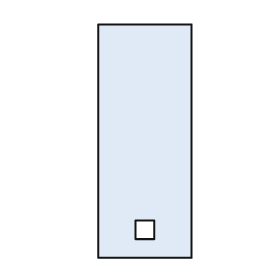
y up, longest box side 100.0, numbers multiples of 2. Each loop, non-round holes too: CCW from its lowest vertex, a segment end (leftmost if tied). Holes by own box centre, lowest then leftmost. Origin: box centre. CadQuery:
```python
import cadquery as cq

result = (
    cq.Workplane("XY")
    .moveTo(-20.0, -50.0)
    .lineTo(20.0, -50.0)
    .lineTo(20.0, 50.0)
    .lineTo(-20.0, 50.0)
    .close()
    .moveTo(-4.0, -42.0)
    .lineTo(4.0, -42.0)
    .lineTo(4.0, -34.0)
    .lineTo(-4.0, -34.0)
    .close()
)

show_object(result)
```